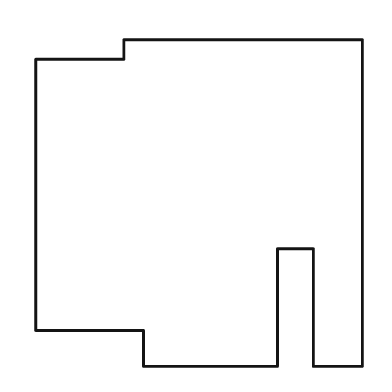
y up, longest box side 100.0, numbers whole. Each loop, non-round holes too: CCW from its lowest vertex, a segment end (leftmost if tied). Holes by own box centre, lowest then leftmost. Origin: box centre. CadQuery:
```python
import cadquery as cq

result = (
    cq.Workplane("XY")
    .moveTo(-17.0, -50.0)
    .lineTo(24.0, -50.0)
    .lineTo(24.0, -14.0)
    .lineTo(35.0, -14.0)
    .lineTo(35.0, -50.0)
    .lineTo(50.0, -50.0)
    .lineTo(50.0, 50.0)
    .lineTo(-23.0, 50.0)
    .lineTo(-23.0, 44.0)
    .lineTo(-50.0, 44.0)
    .lineTo(-50.0, -39.0)
    .lineTo(-17.0, -39.0)
    .close()
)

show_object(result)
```